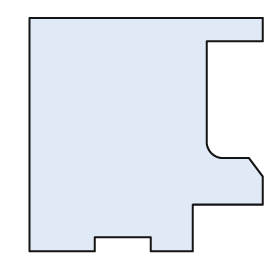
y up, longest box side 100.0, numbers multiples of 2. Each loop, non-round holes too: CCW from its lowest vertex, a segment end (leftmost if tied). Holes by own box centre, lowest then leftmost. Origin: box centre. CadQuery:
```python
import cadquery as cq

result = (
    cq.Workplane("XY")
    .moveTo(-50.0, -50.0)
    .lineTo(-22.0, -50.0)
    .lineTo(-22.0, -44.0)
    .lineTo(2.0, -44.0)
    .lineTo(2.0, -50.0)
    .lineTo(20.0, -50.0)
    .lineTo(20.0, -30.0)
    .lineTo(50.0, -30.0)
    .lineTo(50.0, -18.0)
    .lineTo(44.0, -10.0)
    .lineTo(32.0, -10.0)
    .threePointArc((28.0, -8.0), (26.0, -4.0))
    .lineTo(26.0, 40.0)
    .lineTo(50.0, 40.0)
    .lineTo(50.0, 50.0)
    .lineTo(-50.0, 50.0)
    .close()
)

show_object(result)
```